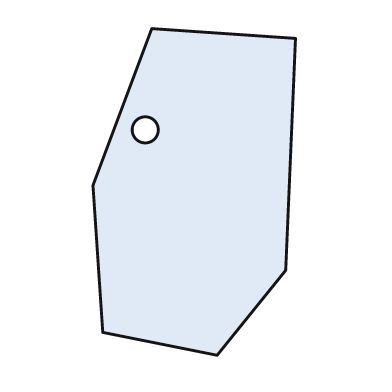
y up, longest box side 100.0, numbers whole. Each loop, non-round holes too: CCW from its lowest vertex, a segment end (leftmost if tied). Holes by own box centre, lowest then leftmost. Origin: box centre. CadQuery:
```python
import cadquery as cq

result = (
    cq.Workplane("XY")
    .moveTo(7.0, -50.0)
    .lineTo(28.0, -24.0)
    .lineTo(31.0, 47.0)
    .lineTo(-13.0, 50.0)
    .lineTo(-31.0, 2.0)
    .lineTo(-28.0, -43.0)
    .close()
    .moveTo(-15.0, 19.0)
    .circle(4.0)
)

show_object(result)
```